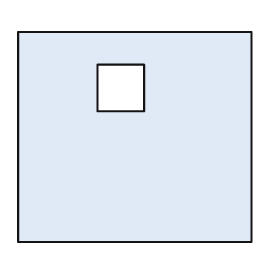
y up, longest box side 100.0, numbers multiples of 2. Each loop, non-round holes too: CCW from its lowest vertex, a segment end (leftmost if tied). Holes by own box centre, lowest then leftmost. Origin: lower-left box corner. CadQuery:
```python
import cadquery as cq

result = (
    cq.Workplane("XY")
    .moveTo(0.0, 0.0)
    .lineTo(100.0, 0.0)
    .lineTo(100.0, 90.0)
    .lineTo(0.0, 90.0)
    .close()
    .moveTo(34.0, 56.0)
    .lineTo(54.0, 56.0)
    .lineTo(54.0, 76.0)
    .lineTo(34.0, 76.0)
    .close()
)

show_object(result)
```